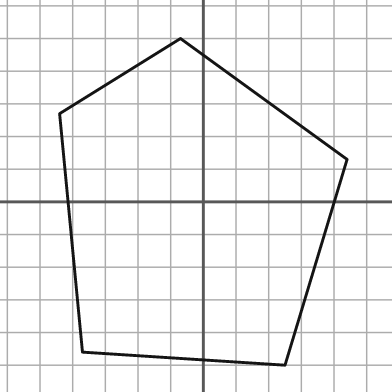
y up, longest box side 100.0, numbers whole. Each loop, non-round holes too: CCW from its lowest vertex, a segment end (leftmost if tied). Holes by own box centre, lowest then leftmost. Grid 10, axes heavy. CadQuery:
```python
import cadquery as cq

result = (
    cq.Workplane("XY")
    .moveTo(25.0, -50.0)
    .lineTo(44.0, 13.0)
    .lineTo(-7.0, 50.0)
    .lineTo(-44.0, 27.0)
    .lineTo(-37.0, -46.0)
    .close()
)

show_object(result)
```